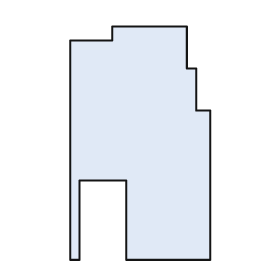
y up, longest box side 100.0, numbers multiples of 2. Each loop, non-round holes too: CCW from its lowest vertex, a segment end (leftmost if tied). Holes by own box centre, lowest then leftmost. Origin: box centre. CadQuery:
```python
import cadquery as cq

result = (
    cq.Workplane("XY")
    .moveTo(-30.0, -50.0)
    .lineTo(-26.0, -50.0)
    .lineTo(-26.0, -16.0)
    .lineTo(-6.0, -16.0)
    .lineTo(-6.0, -50.0)
    .lineTo(30.0, -50.0)
    .lineTo(30.0, 14.0)
    .lineTo(24.0, 14.0)
    .lineTo(24.0, 32.0)
    .lineTo(20.0, 32.0)
    .lineTo(20.0, 50.0)
    .lineTo(-12.0, 50.0)
    .lineTo(-12.0, 44.0)
    .lineTo(-30.0, 44.0)
    .close()
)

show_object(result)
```